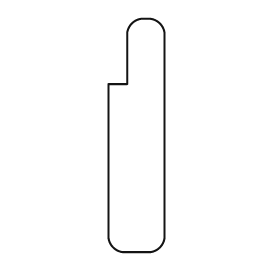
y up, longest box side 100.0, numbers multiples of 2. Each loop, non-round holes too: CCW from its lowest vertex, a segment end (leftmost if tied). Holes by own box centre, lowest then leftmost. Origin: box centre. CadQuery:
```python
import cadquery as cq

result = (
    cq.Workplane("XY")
    .moveTo(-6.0, -50.0)
    .lineTo(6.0, -50.0)
    .threePointArc((10.0, -48.0), (12.0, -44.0))
    .lineTo(12.0, 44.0)
    .threePointArc((10.0, 48.0), (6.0, 50.0))
    .lineTo(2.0, 50.0)
    .threePointArc((-2.0, 48.0), (-4.0, 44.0))
    .lineTo(-4.0, 22.0)
    .lineTo(-12.0, 22.0)
    .lineTo(-12.0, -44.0)
    .threePointArc((-10.0, -48.0), (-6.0, -50.0))
    .close()
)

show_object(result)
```